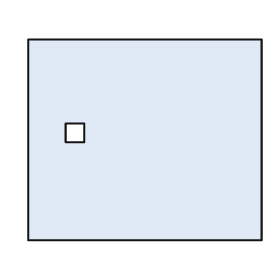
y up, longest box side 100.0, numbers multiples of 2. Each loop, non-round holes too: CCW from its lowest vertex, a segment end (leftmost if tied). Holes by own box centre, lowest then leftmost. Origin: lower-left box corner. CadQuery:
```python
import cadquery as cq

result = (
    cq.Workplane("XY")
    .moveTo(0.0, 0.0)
    .lineTo(100.0, 0.0)
    .lineTo(100.0, 86.0)
    .lineTo(0.0, 86.0)
    .close()
    .moveTo(16.0, 42.0)
    .lineTo(24.0, 42.0)
    .lineTo(24.0, 50.0)
    .lineTo(16.0, 50.0)
    .close()
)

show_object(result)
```